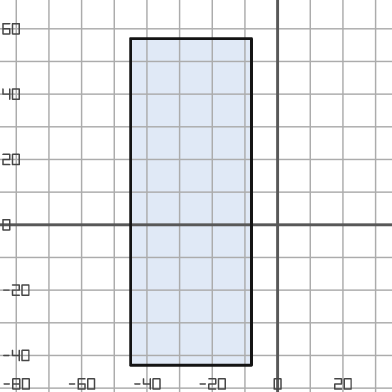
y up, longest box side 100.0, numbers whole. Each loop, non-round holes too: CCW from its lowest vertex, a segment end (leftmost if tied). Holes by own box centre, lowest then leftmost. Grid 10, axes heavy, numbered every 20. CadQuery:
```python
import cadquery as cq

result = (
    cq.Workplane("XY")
    .moveTo(-45.0, -43.0)
    .lineTo(-8.0, -43.0)
    .lineTo(-8.0, 57.0)
    .lineTo(-45.0, 57.0)
    .close()
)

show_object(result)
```